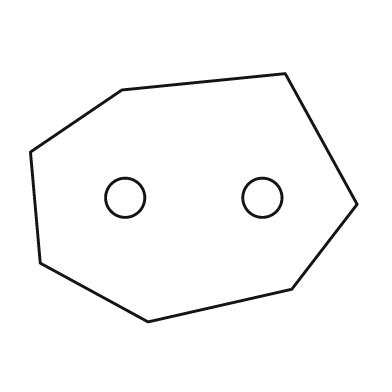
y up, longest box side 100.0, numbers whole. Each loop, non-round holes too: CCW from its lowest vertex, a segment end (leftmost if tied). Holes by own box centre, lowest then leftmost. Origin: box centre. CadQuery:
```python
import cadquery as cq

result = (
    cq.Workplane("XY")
    .moveTo(-14.0, -38.0)
    .lineTo(30.0, -28.0)
    .lineTo(50.0, -2.0)
    .lineTo(28.0, 38.0)
    .lineTo(-22.0, 33.0)
    .lineTo(-50.0, 14.0)
    .lineTo(-47.0, -20.0)
    .close()
    .moveTo(-21.0, 0.0)
    .circle(6.0)
    .moveTo(21.0, 0.0)
    .circle(6.0)
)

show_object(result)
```